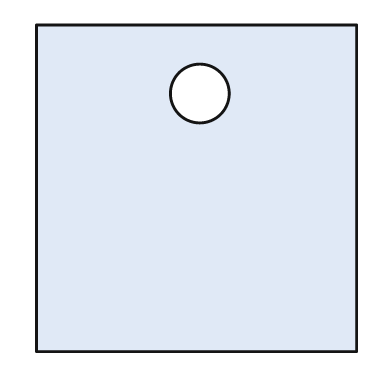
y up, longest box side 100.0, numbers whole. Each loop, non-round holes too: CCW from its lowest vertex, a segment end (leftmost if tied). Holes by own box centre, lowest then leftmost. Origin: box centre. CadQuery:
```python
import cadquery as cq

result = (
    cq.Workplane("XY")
    .moveTo(-49.0, -50.0)
    .lineTo(49.0, -50.0)
    .lineTo(49.0, 50.0)
    .lineTo(-49.0, 50.0)
    .close()
    .moveTo(1.0, 29.0)
    .circle(9.0)
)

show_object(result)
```